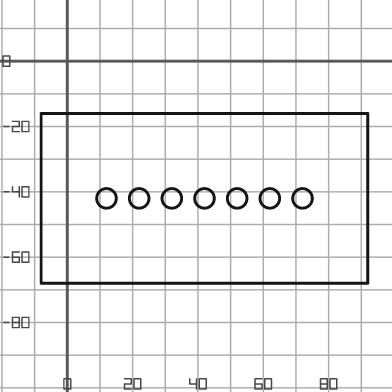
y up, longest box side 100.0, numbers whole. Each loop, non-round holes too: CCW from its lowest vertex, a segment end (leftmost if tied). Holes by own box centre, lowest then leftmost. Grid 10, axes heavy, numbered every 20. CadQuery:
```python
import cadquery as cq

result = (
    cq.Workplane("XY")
    .moveTo(-8.0, -68.0)
    .lineTo(92.0, -68.0)
    .lineTo(92.0, -16.0)
    .lineTo(-8.0, -16.0)
    .close()
    .moveTo(12.0, -42.0)
    .circle(3.0)
    .moveTo(22.0, -42.0)
    .circle(3.0)
    .moveTo(32.0, -42.0)
    .circle(3.0)
    .moveTo(42.0, -42.0)
    .circle(3.0)
    .moveTo(52.0, -42.0)
    .circle(3.0)
    .moveTo(62.0, -42.0)
    .circle(3.0)
    .moveTo(72.0, -42.0)
    .circle(3.0)
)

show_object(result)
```